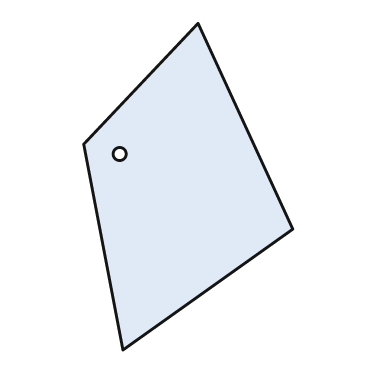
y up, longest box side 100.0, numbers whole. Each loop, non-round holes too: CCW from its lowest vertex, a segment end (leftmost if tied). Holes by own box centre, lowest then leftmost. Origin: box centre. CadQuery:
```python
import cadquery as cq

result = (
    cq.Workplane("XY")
    .moveTo(-20.0, -50.0)
    .lineTo(32.0, -13.0)
    .lineTo(3.0, 50.0)
    .lineTo(-32.0, 13.0)
    .close()
    .moveTo(-21.0, 10.0)
    .circle(2.0)
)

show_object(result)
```